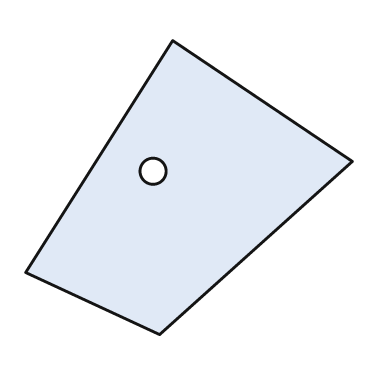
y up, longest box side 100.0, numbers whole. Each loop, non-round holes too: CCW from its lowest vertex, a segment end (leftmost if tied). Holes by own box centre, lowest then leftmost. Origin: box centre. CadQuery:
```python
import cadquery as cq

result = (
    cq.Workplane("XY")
    .moveTo(-9.0, -45.0)
    .lineTo(50.0, 8.0)
    .lineTo(-5.0, 45.0)
    .lineTo(-50.0, -26.0)
    .close()
    .moveTo(-11.0, 5.0)
    .circle(4.0)
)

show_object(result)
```